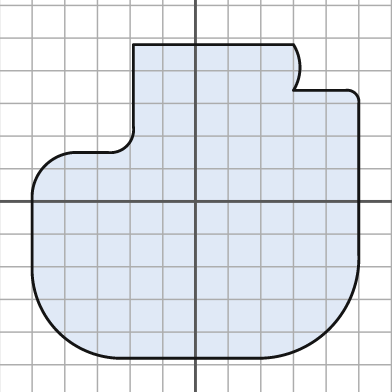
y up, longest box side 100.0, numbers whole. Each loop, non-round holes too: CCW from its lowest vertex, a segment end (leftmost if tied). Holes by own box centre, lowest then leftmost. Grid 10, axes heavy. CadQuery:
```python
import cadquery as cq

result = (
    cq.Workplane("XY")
    .moveTo(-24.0, -48.0)
    .lineTo(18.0, -48.0)
    .threePointArc((41.0, -39.0), (50.0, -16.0))
    .lineTo(50.0, 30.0)
    .threePointArc((49.0, 33.0), (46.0, 34.0))
    .lineTo(30.0, 34.0)
    .threePointArc((32.0, 41.0), (30.0, 48.0))
    .lineTo(-19.0, 48.0)
    .lineTo(-19.0, 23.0)
    .threePointArc((-21.0, 17.0), (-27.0, 15.0))
    .lineTo(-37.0, 15.0)
    .threePointArc((-46.0, 11.0), (-50.0, 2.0))
    .lineTo(-50.0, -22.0)
    .threePointArc((-42.0, -40.0), (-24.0, -48.0))
    .close()
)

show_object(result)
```